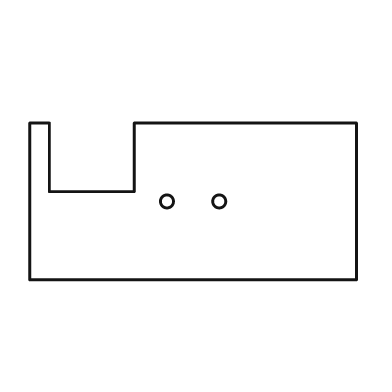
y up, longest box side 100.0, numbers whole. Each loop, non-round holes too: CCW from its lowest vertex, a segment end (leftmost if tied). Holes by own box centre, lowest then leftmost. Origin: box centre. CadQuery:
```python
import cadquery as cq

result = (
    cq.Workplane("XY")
    .moveTo(-50.0, -24.0)
    .lineTo(50.0, -24.0)
    .lineTo(50.0, 24.0)
    .lineTo(-18.0, 24.0)
    .lineTo(-18.0, 3.0)
    .lineTo(-44.0, 3.0)
    .lineTo(-44.0, 24.0)
    .lineTo(-50.0, 24.0)
    .close()
    .moveTo(-8.0, 0.0)
    .circle(2.0)
    .moveTo(8.0, 0.0)
    .circle(2.0)
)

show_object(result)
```